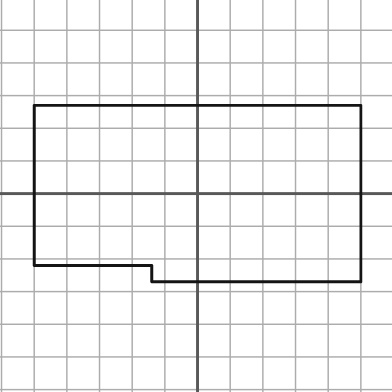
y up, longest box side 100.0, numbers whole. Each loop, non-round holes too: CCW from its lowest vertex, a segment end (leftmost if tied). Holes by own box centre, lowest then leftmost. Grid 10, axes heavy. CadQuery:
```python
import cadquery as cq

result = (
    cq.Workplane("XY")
    .moveTo(-14.0, -27.0)
    .lineTo(50.0, -27.0)
    .lineTo(50.0, 27.0)
    .lineTo(-50.0, 27.0)
    .lineTo(-50.0, -22.0)
    .lineTo(-14.0, -22.0)
    .close()
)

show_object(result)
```